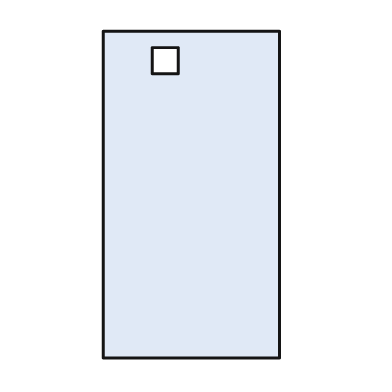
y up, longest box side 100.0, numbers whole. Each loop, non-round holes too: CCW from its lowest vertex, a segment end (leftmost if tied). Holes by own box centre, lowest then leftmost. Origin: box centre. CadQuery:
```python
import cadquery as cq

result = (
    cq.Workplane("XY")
    .moveTo(-27.0, -50.0)
    .lineTo(27.0, -50.0)
    .lineTo(27.0, 50.0)
    .lineTo(-27.0, 50.0)
    .close()
    .moveTo(-12.0, 37.0)
    .lineTo(-4.0, 37.0)
    .lineTo(-4.0, 45.0)
    .lineTo(-12.0, 45.0)
    .close()
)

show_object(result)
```